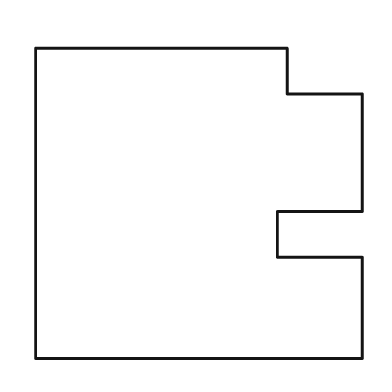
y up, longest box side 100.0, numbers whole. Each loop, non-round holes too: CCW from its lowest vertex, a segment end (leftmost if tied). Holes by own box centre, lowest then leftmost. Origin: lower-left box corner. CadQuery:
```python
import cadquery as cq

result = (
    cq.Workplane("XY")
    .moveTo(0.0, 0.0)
    .lineTo(100.0, 0.0)
    .lineTo(100.0, 31.0)
    .lineTo(74.0, 31.0)
    .lineTo(74.0, 45.0)
    .lineTo(100.0, 45.0)
    .lineTo(100.0, 81.0)
    .lineTo(77.0, 81.0)
    .lineTo(77.0, 95.0)
    .lineTo(0.0, 95.0)
    .close()
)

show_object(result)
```